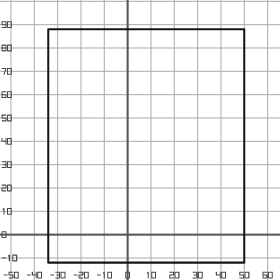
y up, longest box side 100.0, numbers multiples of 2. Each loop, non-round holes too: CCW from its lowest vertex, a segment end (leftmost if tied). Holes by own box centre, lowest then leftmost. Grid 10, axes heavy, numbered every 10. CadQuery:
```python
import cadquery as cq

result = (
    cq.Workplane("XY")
    .moveTo(-34.0, -12.0)
    .lineTo(50.0, -12.0)
    .lineTo(50.0, 88.0)
    .lineTo(-34.0, 88.0)
    .close()
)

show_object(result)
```